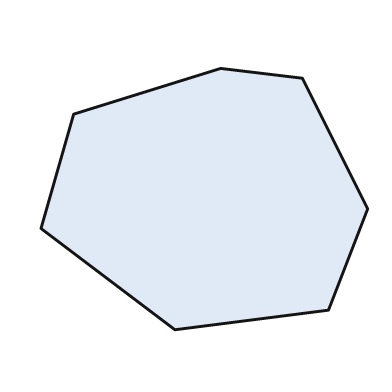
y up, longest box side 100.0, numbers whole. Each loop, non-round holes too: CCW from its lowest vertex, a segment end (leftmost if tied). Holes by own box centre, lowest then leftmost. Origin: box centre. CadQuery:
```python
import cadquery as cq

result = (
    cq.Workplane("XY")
    .moveTo(-9.0, -40.0)
    .lineTo(38.0, -34.0)
    .lineTo(50.0, -3.0)
    .lineTo(30.0, 37.0)
    .lineTo(5.0, 40.0)
    .lineTo(-40.0, 26.0)
    .lineTo(-50.0, -9.0)
    .close()
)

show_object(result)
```